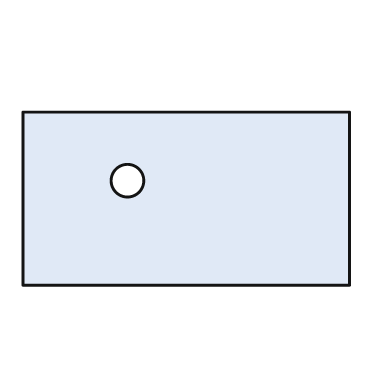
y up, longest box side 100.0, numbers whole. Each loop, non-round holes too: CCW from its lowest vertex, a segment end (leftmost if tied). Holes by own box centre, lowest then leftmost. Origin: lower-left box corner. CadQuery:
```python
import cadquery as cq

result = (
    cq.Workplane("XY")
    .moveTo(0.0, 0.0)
    .lineTo(100.0, 0.0)
    .lineTo(100.0, 53.0)
    .lineTo(0.0, 53.0)
    .close()
    .moveTo(32.0, 32.0)
    .circle(5.0)
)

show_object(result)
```